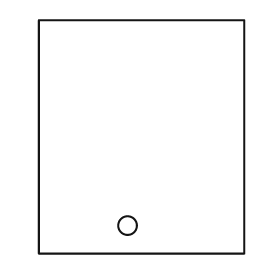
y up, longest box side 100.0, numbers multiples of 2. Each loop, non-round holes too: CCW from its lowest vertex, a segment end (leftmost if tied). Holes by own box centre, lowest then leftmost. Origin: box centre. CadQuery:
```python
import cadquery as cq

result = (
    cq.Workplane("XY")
    .moveTo(-44.0, -50.0)
    .lineTo(44.0, -50.0)
    .lineTo(44.0, 50.0)
    .lineTo(-44.0, 50.0)
    .close()
    .moveTo(-6.0, -38.0)
    .circle(4.0)
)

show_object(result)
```